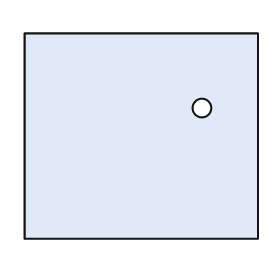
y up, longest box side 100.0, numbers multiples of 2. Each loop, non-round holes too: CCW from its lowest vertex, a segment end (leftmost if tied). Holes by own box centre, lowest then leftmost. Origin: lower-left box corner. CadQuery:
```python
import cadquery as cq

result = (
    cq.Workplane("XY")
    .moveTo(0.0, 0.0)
    .lineTo(100.0, 0.0)
    .lineTo(100.0, 88.0)
    .lineTo(0.0, 88.0)
    .close()
    .moveTo(76.0, 56.0)
    .circle(4.0)
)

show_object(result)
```